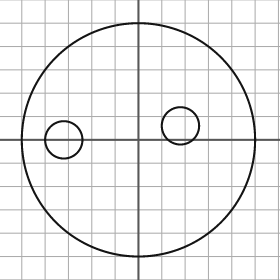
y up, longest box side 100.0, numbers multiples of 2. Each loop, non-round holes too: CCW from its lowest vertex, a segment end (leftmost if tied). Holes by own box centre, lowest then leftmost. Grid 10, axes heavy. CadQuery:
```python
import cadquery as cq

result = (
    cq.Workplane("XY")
    .moveTo(0.0, 0.0)
    .circle(50.0)
    .moveTo(-32.0, 0.0)
    .circle(8.0)
    .moveTo(18.0, 6.0)
    .circle(8.0)
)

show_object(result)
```